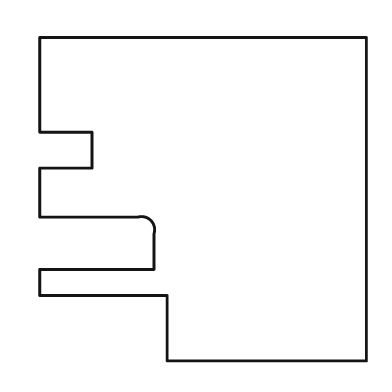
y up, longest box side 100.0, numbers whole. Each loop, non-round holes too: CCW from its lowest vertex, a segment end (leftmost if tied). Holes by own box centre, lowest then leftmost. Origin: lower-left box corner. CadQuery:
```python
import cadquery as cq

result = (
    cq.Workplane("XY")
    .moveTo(39.0, 0.0)
    .lineTo(100.0, 0.0)
    .lineTo(100.0, 99.0)
    .lineTo(0.0, 99.0)
    .lineTo(0.0, 70.0)
    .lineTo(16.0, 70.0)
    .lineTo(16.0, 59.0)
    .lineTo(0.0, 59.0)
    .lineTo(0.0, 44.0)
    .lineTo(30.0, 44.0)
    .threePointArc((34.0, 43.0), (35.0, 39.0))
    .lineTo(35.0, 28.0)
    .lineTo(0.0, 28.0)
    .lineTo(0.0, 20.0)
    .lineTo(39.0, 20.0)
    .close()
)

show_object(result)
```